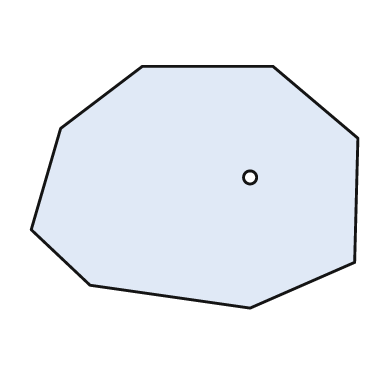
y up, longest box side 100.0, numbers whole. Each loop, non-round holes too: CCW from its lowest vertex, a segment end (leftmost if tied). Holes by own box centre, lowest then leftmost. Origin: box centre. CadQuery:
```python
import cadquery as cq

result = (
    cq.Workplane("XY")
    .moveTo(17.0, -37.0)
    .lineTo(49.0, -23.0)
    .lineTo(50.0, 15.0)
    .lineTo(24.0, 37.0)
    .lineTo(-16.0, 37.0)
    .lineTo(-41.0, 18.0)
    .lineTo(-50.0, -13.0)
    .lineTo(-32.0, -30.0)
    .close()
    .moveTo(17.0, 3.0)
    .circle(2.0)
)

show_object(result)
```